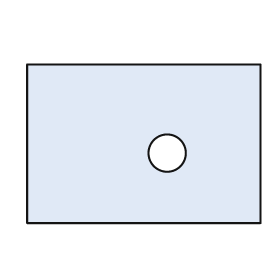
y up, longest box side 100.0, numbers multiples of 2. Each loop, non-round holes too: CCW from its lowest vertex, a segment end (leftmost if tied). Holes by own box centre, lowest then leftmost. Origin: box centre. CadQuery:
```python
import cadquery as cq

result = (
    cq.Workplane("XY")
    .moveTo(-50.0, -34.0)
    .lineTo(50.0, -34.0)
    .lineTo(50.0, 34.0)
    .lineTo(-50.0, 34.0)
    .close()
    .moveTo(10.0, -4.0)
    .circle(8.0)
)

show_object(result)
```